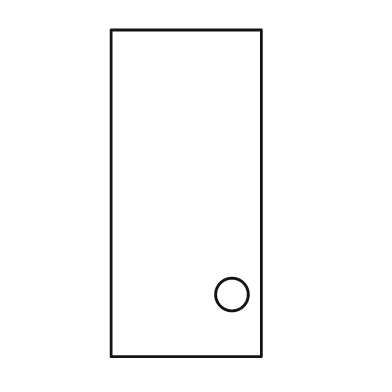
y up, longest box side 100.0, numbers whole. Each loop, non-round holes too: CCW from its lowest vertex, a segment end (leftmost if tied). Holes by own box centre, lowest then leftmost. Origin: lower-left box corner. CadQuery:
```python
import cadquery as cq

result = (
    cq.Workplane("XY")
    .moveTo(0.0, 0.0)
    .lineTo(46.0, 0.0)
    .lineTo(46.0, 100.0)
    .lineTo(0.0, 100.0)
    .close()
    .moveTo(37.0, 19.0)
    .circle(5.0)
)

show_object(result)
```